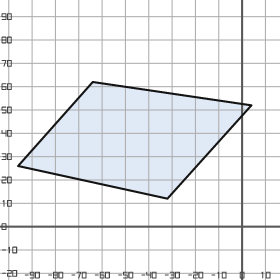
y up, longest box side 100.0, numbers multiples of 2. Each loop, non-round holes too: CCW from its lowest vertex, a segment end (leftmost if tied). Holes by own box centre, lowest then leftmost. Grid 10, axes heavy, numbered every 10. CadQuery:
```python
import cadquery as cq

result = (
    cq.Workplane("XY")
    .moveTo(-32.0, 12.0)
    .lineTo(4.0, 52.0)
    .lineTo(-64.0, 62.0)
    .lineTo(-96.0, 26.0)
    .close()
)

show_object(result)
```